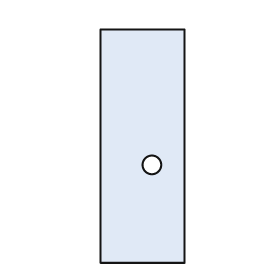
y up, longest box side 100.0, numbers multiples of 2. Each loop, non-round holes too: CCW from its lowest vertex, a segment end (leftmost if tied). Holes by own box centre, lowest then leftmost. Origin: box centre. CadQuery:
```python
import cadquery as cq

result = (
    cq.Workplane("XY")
    .moveTo(-18.0, -50.0)
    .lineTo(18.0, -50.0)
    .lineTo(18.0, 50.0)
    .lineTo(-18.0, 50.0)
    .close()
    .moveTo(4.0, -8.0)
    .circle(4.0)
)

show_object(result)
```